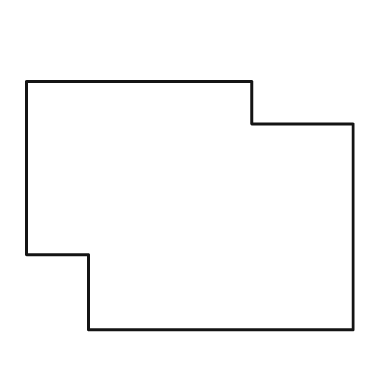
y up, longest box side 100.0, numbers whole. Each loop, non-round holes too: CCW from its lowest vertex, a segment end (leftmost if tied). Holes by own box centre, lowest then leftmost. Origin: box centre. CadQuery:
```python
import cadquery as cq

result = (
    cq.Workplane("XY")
    .moveTo(-31.0, -38.0)
    .lineTo(50.0, -38.0)
    .lineTo(50.0, 25.0)
    .lineTo(19.0, 25.0)
    .lineTo(19.0, 38.0)
    .lineTo(-50.0, 38.0)
    .lineTo(-50.0, -15.0)
    .lineTo(-31.0, -15.0)
    .close()
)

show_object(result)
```